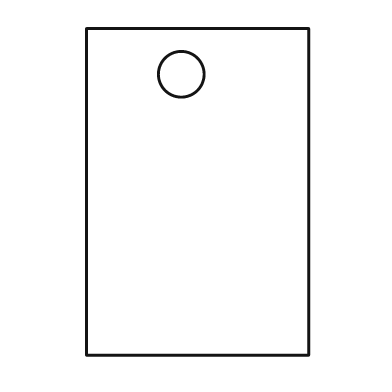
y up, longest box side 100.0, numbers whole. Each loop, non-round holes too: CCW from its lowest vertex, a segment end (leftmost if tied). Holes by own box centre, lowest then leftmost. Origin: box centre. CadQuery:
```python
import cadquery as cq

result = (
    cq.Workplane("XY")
    .moveTo(-34.0, -50.0)
    .lineTo(34.0, -50.0)
    .lineTo(34.0, 50.0)
    .lineTo(-34.0, 50.0)
    .close()
    .moveTo(-5.0, 36.0)
    .circle(7.0)
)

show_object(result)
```